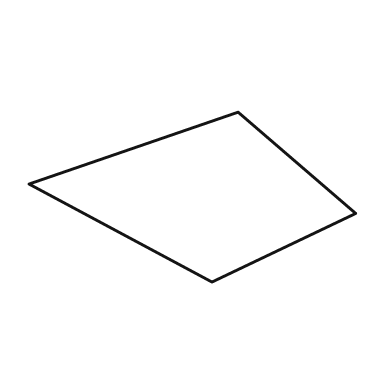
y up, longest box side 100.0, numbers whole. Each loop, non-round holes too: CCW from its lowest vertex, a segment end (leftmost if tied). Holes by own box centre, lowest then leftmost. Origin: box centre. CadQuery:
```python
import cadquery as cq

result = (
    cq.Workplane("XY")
    .moveTo(6.0, -26.0)
    .lineTo(50.0, -5.0)
    .lineTo(14.0, 26.0)
    .lineTo(-50.0, 4.0)
    .close()
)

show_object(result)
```